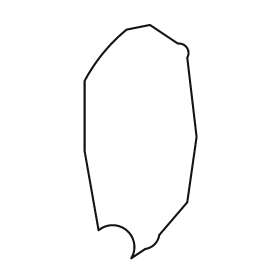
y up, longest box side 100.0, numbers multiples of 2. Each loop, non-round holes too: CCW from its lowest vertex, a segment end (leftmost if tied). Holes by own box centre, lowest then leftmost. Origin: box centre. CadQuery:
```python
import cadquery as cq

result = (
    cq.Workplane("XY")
    .moveTo(-4.0, -50.0)
    .lineTo(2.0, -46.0)
    .threePointArc((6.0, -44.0), (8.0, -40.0))
    .lineTo(20.0, -26.0)
    .lineTo(24.0, 2.0)
    .lineTo(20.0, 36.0)
    .threePointArc((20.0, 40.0), (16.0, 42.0))
    .lineTo(4.0, 50.0)
    .lineTo(-6.0, 48.0)
    .threePointArc((-16.0, 38.0), (-24.0, 26.0))
    .lineTo(-24.0, -4.0)
    .lineTo(-18.0, -38.0)
    .threePointArc((-6.0, -38.0), (-4.0, -50.0))
    .close()
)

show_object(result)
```